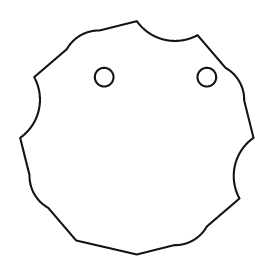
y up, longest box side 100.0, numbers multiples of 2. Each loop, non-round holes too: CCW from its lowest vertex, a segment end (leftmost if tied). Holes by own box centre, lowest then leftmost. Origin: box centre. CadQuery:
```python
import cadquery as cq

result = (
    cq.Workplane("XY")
    .moveTo(0.0, -50.0)
    .lineTo(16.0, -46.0)
    .threePointArc((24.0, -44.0), (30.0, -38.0))
    .lineTo(44.0, -26.0)
    .threePointArc((42.0, -12.0), (50.0, 0.0))
    .lineTo(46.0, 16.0)
    .threePointArc((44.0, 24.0), (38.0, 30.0))
    .lineTo(26.0, 44.0)
    .threePointArc((12.0, 42.0), (0.0, 50.0))
    .lineTo(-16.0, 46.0)
    .threePointArc((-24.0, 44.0), (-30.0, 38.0))
    .lineTo(-44.0, 26.0)
    .threePointArc((-42.0, 12.0), (-50.0, 0.0))
    .lineTo(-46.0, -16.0)
    .threePointArc((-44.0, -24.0), (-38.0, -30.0))
    .lineTo(-26.0, -44.0)
    .close()
    .moveTo(-14.0, 26.0)
    .circle(4.0)
    .moveTo(30.0, 26.0)
    .circle(4.0)
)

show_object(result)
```